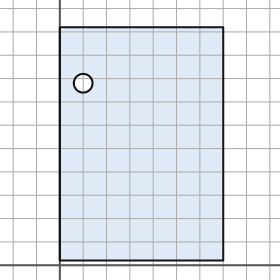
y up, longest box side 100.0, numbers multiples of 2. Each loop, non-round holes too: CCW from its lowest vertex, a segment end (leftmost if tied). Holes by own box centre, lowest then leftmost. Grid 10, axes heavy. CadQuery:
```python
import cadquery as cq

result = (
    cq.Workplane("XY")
    .moveTo(0.0, 2.0)
    .lineTo(70.0, 2.0)
    .lineTo(70.0, 102.0)
    .lineTo(0.0, 102.0)
    .close()
    .moveTo(10.0, 78.0)
    .circle(4.0)
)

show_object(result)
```